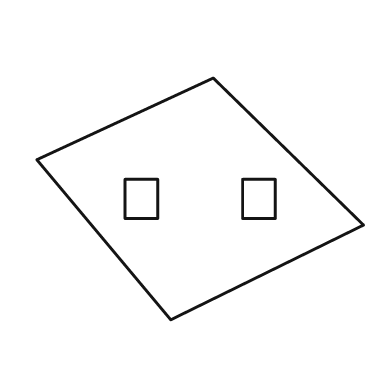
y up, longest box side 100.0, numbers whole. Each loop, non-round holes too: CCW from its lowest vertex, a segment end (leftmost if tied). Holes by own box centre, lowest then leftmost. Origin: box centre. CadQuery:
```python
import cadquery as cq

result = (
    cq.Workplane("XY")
    .moveTo(-9.0, -37.0)
    .lineTo(50.0, -8.0)
    .lineTo(4.0, 37.0)
    .lineTo(-50.0, 12.0)
    .close()
    .moveTo(-23.0, -6.0)
    .lineTo(-13.0, -6.0)
    .lineTo(-13.0, 6.0)
    .lineTo(-23.0, 6.0)
    .close()
    .moveTo(13.0, -6.0)
    .lineTo(23.0, -6.0)
    .lineTo(23.0, 6.0)
    .lineTo(13.0, 6.0)
    .close()
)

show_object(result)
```